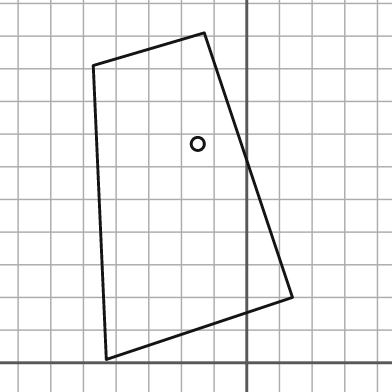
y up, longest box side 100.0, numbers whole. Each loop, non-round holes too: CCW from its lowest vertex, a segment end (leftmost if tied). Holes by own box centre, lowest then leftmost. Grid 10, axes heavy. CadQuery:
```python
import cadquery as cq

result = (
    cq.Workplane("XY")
    .moveTo(-43.0, 1.0)
    .lineTo(14.0, 20.0)
    .lineTo(-13.0, 101.0)
    .lineTo(-47.0, 91.0)
    .close()
    .moveTo(-15.0, 67.0)
    .circle(2.0)
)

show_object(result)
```